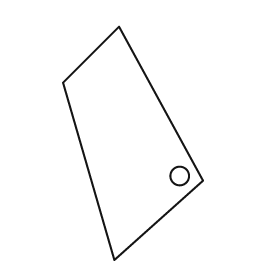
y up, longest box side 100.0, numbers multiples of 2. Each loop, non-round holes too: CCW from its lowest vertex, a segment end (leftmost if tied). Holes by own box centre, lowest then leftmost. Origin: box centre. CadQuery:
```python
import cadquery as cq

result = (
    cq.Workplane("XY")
    .moveTo(-8.0, -50.0)
    .lineTo(30.0, -16.0)
    .lineTo(-6.0, 50.0)
    .lineTo(-30.0, 26.0)
    .close()
    .moveTo(20.0, -14.0)
    .circle(4.0)
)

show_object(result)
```